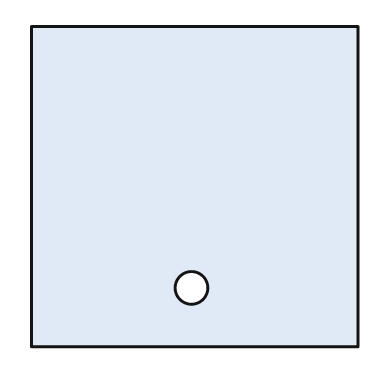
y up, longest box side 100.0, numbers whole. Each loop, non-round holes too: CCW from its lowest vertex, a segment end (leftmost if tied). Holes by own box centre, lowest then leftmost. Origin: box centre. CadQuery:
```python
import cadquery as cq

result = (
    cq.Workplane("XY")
    .moveTo(-50.0, -49.0)
    .lineTo(50.0, -49.0)
    .lineTo(50.0, 49.0)
    .lineTo(-50.0, 49.0)
    .close()
    .moveTo(-1.0, -31.0)
    .circle(5.0)
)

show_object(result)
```